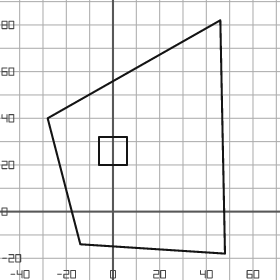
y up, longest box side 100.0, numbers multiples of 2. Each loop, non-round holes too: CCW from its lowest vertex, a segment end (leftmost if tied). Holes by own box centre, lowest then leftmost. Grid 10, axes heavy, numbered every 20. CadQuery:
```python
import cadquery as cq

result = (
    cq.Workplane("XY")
    .moveTo(48.0, -18.0)
    .lineTo(46.0, 82.0)
    .lineTo(-28.0, 40.0)
    .lineTo(-14.0, -14.0)
    .close()
    .moveTo(-6.0, 20.0)
    .lineTo(6.0, 20.0)
    .lineTo(6.0, 32.0)
    .lineTo(-6.0, 32.0)
    .close()
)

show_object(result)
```